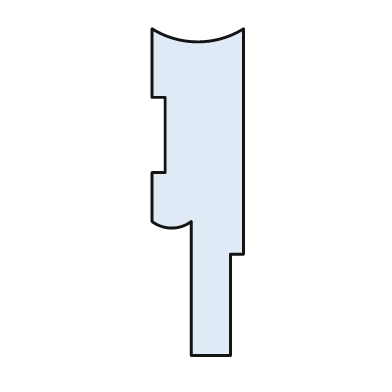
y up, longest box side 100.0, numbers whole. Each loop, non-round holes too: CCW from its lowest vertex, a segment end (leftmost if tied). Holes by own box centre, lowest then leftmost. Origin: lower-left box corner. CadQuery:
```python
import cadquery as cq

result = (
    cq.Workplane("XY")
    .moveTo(12.0, 0.0)
    .lineTo(24.0, 0.0)
    .lineTo(24.0, 31.0)
    .lineTo(28.0, 31.0)
    .lineTo(28.0, 100.0)
    .threePointArc((14.0, 96.0), (0.0, 100.0))
    .lineTo(0.0, 79.0)
    .lineTo(4.0, 79.0)
    .lineTo(4.0, 56.0)
    .lineTo(0.0, 56.0)
    .lineTo(0.0, 41.0)
    .threePointArc((6.0, 39.0), (12.0, 41.0))
    .close()
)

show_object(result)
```